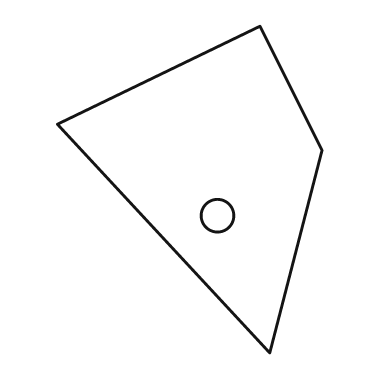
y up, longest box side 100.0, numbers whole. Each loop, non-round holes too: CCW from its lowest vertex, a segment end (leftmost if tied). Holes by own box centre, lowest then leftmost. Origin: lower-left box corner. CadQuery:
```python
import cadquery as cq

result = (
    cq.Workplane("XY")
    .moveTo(65.0, 0.0)
    .lineTo(81.0, 62.0)
    .lineTo(62.0, 100.0)
    .lineTo(0.0, 70.0)
    .close()
    .moveTo(49.0, 42.0)
    .circle(5.0)
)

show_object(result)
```